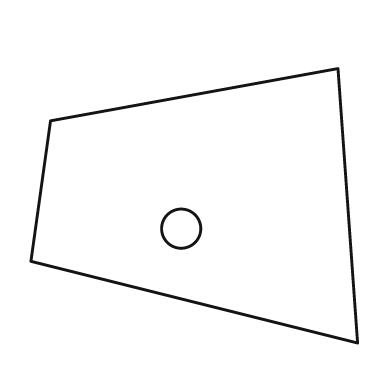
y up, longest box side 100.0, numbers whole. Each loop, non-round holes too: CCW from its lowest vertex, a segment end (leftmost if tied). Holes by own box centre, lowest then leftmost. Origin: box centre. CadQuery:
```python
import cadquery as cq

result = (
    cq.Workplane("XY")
    .moveTo(50.0, -42.0)
    .lineTo(44.0, 42.0)
    .lineTo(-44.0, 26.0)
    .lineTo(-50.0, -17.0)
    .close()
    .moveTo(-4.0, -7.0)
    .circle(6.0)
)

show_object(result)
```